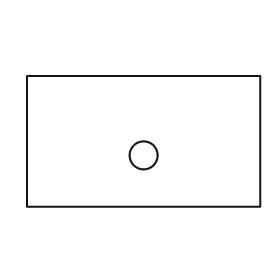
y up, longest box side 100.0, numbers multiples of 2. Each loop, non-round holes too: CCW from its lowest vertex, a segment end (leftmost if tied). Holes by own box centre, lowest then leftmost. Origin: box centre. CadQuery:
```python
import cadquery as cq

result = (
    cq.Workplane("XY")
    .moveTo(-50.0, -28.0)
    .lineTo(50.0, -28.0)
    .lineTo(50.0, 28.0)
    .lineTo(-50.0, 28.0)
    .close()
    .moveTo(0.0, -6.0)
    .circle(6.0)
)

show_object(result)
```